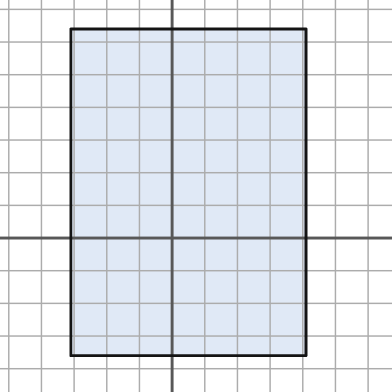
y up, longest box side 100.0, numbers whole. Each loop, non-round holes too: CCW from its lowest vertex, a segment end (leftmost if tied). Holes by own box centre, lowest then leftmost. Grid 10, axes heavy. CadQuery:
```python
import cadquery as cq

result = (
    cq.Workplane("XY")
    .moveTo(-31.0, -36.0)
    .lineTo(41.0, -36.0)
    .lineTo(41.0, 64.0)
    .lineTo(-31.0, 64.0)
    .close()
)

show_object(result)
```